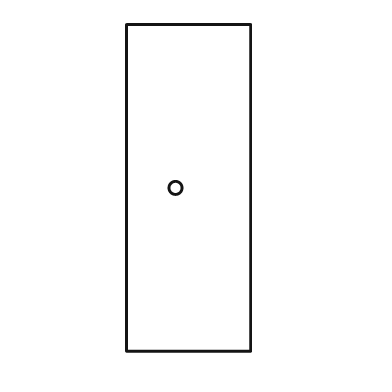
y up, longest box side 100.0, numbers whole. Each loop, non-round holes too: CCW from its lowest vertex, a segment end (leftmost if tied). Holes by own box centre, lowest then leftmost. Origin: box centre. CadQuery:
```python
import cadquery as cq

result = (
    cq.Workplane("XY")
    .moveTo(-19.0, -50.0)
    .lineTo(19.0, -50.0)
    .lineTo(19.0, 50.0)
    .lineTo(-19.0, 50.0)
    .close()
    .moveTo(-4.0, 0.0)
    .circle(2.0)
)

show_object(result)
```